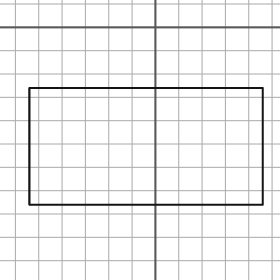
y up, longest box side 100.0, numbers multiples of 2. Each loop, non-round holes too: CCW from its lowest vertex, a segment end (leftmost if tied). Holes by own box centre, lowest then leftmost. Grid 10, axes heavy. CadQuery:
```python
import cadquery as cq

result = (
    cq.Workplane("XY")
    .moveTo(-54.0, -76.0)
    .lineTo(46.0, -76.0)
    .lineTo(46.0, -26.0)
    .lineTo(-54.0, -26.0)
    .close()
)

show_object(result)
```